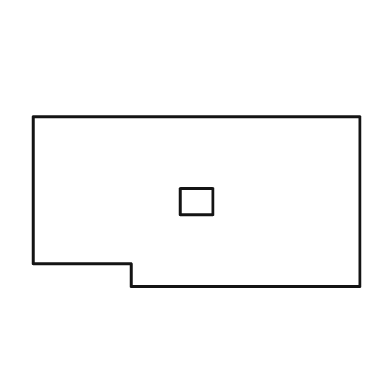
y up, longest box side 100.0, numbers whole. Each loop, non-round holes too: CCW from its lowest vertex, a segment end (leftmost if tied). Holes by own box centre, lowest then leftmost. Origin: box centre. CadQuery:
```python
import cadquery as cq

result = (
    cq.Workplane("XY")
    .moveTo(-20.0, -26.0)
    .lineTo(50.0, -26.0)
    .lineTo(50.0, 26.0)
    .lineTo(-50.0, 26.0)
    .lineTo(-50.0, -19.0)
    .lineTo(-20.0, -19.0)
    .close()
    .moveTo(-5.0, -4.0)
    .lineTo(5.0, -4.0)
    .lineTo(5.0, 4.0)
    .lineTo(-5.0, 4.0)
    .close()
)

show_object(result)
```